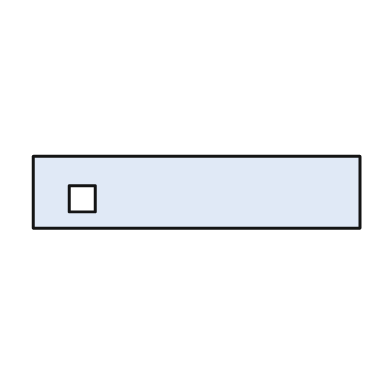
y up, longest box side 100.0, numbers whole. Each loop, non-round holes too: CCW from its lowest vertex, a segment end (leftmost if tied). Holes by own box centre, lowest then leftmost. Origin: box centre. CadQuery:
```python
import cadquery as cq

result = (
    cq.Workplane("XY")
    .moveTo(-50.0, -11.0)
    .lineTo(50.0, -11.0)
    .lineTo(50.0, 11.0)
    .lineTo(-50.0, 11.0)
    .close()
    .moveTo(-39.0, -6.0)
    .lineTo(-31.0, -6.0)
    .lineTo(-31.0, 2.0)
    .lineTo(-39.0, 2.0)
    .close()
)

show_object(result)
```